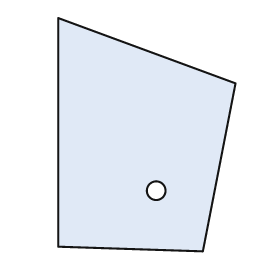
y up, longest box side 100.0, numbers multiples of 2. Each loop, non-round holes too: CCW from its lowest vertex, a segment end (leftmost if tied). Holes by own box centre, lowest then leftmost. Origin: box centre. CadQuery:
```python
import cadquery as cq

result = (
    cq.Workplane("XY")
    .moveTo(24.0, -50.0)
    .lineTo(38.0, 22.0)
    .lineTo(-38.0, 50.0)
    .lineTo(-38.0, -48.0)
    .close()
    .moveTo(4.0, -24.0)
    .circle(4.0)
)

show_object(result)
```